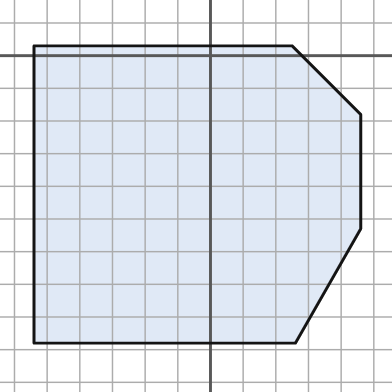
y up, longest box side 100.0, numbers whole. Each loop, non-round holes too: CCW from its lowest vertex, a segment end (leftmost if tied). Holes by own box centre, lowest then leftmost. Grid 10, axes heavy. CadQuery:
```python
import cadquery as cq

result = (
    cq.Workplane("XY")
    .moveTo(-54.0, -88.0)
    .lineTo(26.0, -88.0)
    .lineTo(46.0, -53.0)
    .lineTo(46.0, -18.0)
    .lineTo(25.0, 3.0)
    .lineTo(-54.0, 3.0)
    .close()
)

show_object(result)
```